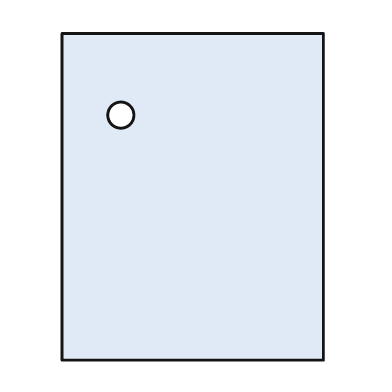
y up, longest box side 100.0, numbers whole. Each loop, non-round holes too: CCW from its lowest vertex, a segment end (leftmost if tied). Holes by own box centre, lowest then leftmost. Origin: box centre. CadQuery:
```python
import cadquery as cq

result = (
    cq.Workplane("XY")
    .moveTo(-40.0, -50.0)
    .lineTo(40.0, -50.0)
    .lineTo(40.0, 50.0)
    .lineTo(-40.0, 50.0)
    .close()
    .moveTo(-22.0, 25.0)
    .circle(4.0)
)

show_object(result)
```